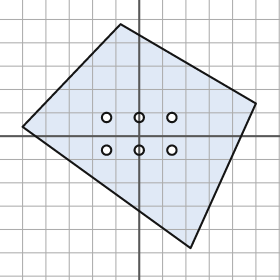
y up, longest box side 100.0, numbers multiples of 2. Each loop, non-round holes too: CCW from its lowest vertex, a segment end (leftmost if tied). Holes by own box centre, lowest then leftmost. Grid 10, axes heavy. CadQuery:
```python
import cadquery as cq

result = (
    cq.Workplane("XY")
    .moveTo(22.0, -48.0)
    .lineTo(50.0, 14.0)
    .lineTo(-8.0, 48.0)
    .lineTo(-50.0, 4.0)
    .close()
    .moveTo(-14.0, -6.0)
    .circle(2.0)
    .moveTo(0.0, -6.0)
    .circle(2.0)
    .moveTo(14.0, -6.0)
    .circle(2.0)
    .moveTo(-14.0, 8.0)
    .circle(2.0)
    .moveTo(0.0, 8.0)
    .circle(2.0)
    .moveTo(14.0, 8.0)
    .circle(2.0)
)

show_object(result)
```